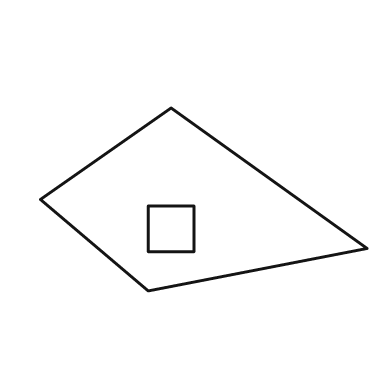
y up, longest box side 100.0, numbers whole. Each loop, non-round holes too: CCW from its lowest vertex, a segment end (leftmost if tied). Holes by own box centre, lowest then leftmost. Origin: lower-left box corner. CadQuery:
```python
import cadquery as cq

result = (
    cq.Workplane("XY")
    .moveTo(33.0, 0.0)
    .lineTo(100.0, 13.0)
    .lineTo(40.0, 56.0)
    .lineTo(0.0, 28.0)
    .close()
    .moveTo(33.0, 12.0)
    .lineTo(47.0, 12.0)
    .lineTo(47.0, 26.0)
    .lineTo(33.0, 26.0)
    .close()
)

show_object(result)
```